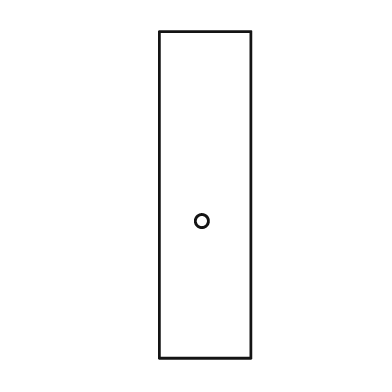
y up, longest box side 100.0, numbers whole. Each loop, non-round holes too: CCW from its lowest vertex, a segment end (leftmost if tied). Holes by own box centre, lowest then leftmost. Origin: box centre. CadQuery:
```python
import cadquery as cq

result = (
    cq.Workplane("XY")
    .moveTo(-14.0, -50.0)
    .lineTo(14.0, -50.0)
    .lineTo(14.0, 50.0)
    .lineTo(-14.0, 50.0)
    .close()
    .moveTo(-1.0, -8.0)
    .circle(2.0)
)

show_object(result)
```